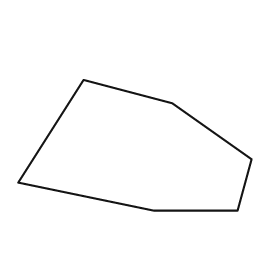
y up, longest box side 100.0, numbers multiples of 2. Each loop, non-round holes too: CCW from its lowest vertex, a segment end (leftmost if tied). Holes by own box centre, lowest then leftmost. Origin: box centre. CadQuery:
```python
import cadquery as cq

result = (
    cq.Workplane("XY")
    .moveTo(8.0, -28.0)
    .lineTo(44.0, -28.0)
    .lineTo(50.0, -6.0)
    .lineTo(16.0, 18.0)
    .lineTo(-22.0, 28.0)
    .lineTo(-50.0, -16.0)
    .close()
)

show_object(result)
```